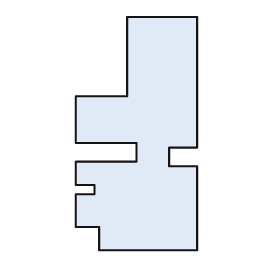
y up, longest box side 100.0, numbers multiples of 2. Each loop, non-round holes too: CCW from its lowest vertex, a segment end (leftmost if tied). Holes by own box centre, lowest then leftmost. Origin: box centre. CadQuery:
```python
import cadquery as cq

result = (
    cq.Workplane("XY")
    .moveTo(-16.0, -50.0)
    .lineTo(26.0, -50.0)
    .lineTo(26.0, -14.0)
    .lineTo(14.0, -14.0)
    .lineTo(14.0, -6.0)
    .lineTo(26.0, -6.0)
    .lineTo(26.0, 50.0)
    .lineTo(-4.0, 50.0)
    .lineTo(-4.0, 16.0)
    .lineTo(-26.0, 16.0)
    .lineTo(-26.0, -4.0)
    .lineTo(0.0, -4.0)
    .lineTo(0.0, -12.0)
    .lineTo(-26.0, -12.0)
    .lineTo(-26.0, -22.0)
    .lineTo(-18.0, -22.0)
    .lineTo(-18.0, -26.0)
    .lineTo(-26.0, -26.0)
    .lineTo(-26.0, -40.0)
    .lineTo(-16.0, -40.0)
    .close()
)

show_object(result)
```